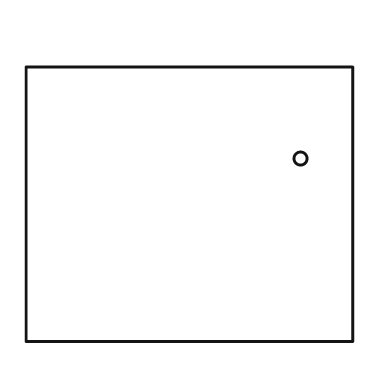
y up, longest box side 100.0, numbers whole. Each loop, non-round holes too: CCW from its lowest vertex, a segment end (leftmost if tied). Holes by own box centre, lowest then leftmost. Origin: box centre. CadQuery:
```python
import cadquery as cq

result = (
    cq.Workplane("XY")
    .moveTo(-50.0, -42.0)
    .lineTo(50.0, -42.0)
    .lineTo(50.0, 42.0)
    .lineTo(-50.0, 42.0)
    .close()
    .moveTo(34.0, 14.0)
    .circle(2.0)
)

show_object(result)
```